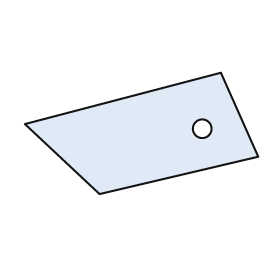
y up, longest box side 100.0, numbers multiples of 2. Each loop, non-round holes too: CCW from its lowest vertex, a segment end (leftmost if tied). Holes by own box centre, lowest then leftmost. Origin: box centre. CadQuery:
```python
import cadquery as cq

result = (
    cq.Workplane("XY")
    .moveTo(-18.0, -26.0)
    .lineTo(50.0, -10.0)
    .lineTo(34.0, 26.0)
    .lineTo(-50.0, 4.0)
    .close()
    .moveTo(26.0, 2.0)
    .circle(4.0)
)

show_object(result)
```